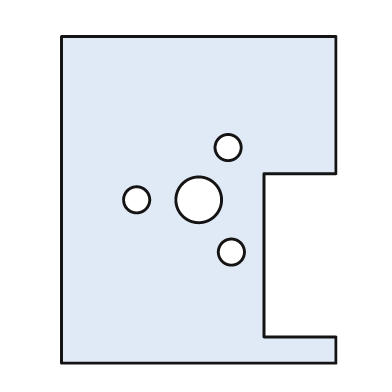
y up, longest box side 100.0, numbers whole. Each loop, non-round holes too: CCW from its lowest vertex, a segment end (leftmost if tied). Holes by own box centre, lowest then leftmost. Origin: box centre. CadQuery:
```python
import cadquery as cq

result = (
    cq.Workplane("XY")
    .moveTo(-42.0, -50.0)
    .lineTo(42.0, -50.0)
    .lineTo(42.0, -42.0)
    .lineTo(20.0, -42.0)
    .lineTo(20.0, 8.0)
    .lineTo(42.0, 8.0)
    .lineTo(42.0, 50.0)
    .lineTo(-42.0, 50.0)
    .close()
    .moveTo(10.0, -16.0)
    .circle(4.0)
    .moveTo(-19.0, 0.0)
    .circle(4.0)
    .moveTo(0.0, 0.0)
    .circle(7.0)
    .moveTo(9.0, 16.0)
    .circle(4.0)
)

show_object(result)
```